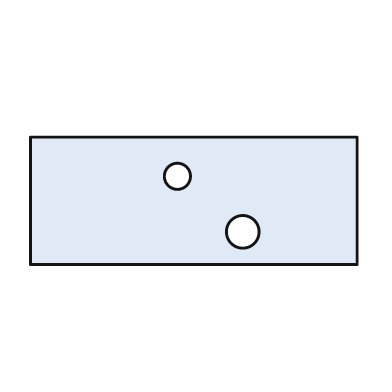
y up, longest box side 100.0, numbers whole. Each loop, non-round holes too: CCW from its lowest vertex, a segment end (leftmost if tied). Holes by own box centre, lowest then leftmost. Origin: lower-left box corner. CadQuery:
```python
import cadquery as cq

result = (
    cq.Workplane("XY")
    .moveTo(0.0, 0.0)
    .lineTo(100.0, 0.0)
    .lineTo(100.0, 39.0)
    .lineTo(0.0, 39.0)
    .close()
    .moveTo(65.0, 10.0)
    .circle(5.0)
    .moveTo(45.0, 27.0)
    .circle(4.0)
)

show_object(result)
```